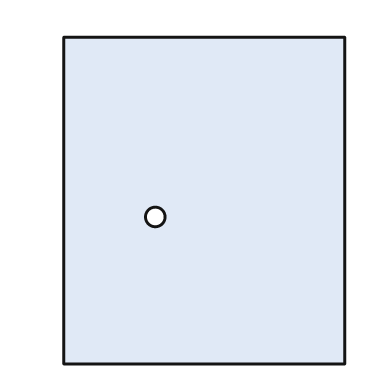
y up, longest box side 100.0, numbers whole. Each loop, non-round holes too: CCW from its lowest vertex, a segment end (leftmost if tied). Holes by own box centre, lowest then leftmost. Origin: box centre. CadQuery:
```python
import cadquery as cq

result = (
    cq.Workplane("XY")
    .moveTo(-43.0, -50.0)
    .lineTo(43.0, -50.0)
    .lineTo(43.0, 50.0)
    .lineTo(-43.0, 50.0)
    .close()
    .moveTo(-15.0, -5.0)
    .circle(3.0)
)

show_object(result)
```